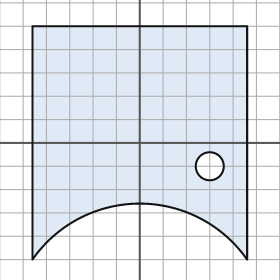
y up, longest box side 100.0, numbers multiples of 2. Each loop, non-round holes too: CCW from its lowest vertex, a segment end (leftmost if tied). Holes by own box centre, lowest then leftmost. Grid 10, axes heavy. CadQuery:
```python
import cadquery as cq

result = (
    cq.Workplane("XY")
    .moveTo(-46.0, -50.0)
    .threePointArc((0.0, -26.0), (46.0, -50.0))
    .lineTo(46.0, 50.0)
    .lineTo(-46.0, 50.0)
    .close()
    .moveTo(30.0, -10.0)
    .circle(6.0)
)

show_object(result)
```